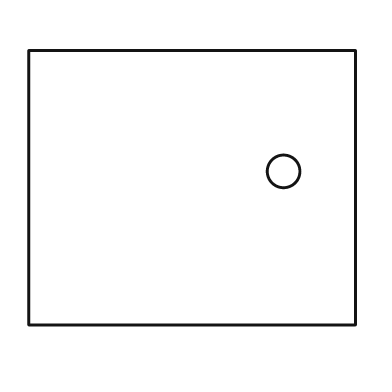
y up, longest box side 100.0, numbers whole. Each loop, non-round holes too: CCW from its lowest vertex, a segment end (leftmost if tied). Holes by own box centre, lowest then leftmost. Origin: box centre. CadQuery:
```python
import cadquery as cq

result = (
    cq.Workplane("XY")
    .moveTo(-50.0, -42.0)
    .lineTo(50.0, -42.0)
    .lineTo(50.0, 42.0)
    .lineTo(-50.0, 42.0)
    .close()
    .moveTo(28.0, 5.0)
    .circle(5.0)
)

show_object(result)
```